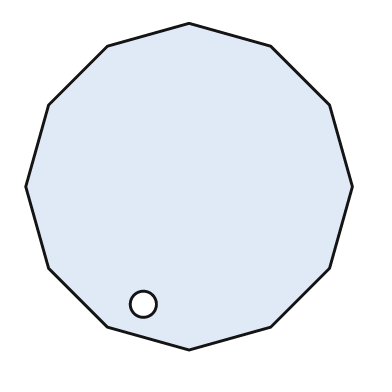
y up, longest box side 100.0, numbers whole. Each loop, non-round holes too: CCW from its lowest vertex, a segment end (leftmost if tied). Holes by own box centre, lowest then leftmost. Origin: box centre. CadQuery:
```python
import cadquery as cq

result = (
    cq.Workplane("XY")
    .moveTo(0.0, -50.0)
    .lineTo(25.0, -43.0)
    .lineTo(43.0, -25.0)
    .lineTo(50.0, 0.0)
    .lineTo(43.0, 25.0)
    .lineTo(25.0, 43.0)
    .lineTo(0.0, 50.0)
    .lineTo(-25.0, 43.0)
    .lineTo(-43.0, 25.0)
    .lineTo(-50.0, 0.0)
    .lineTo(-43.0, -25.0)
    .lineTo(-25.0, -43.0)
    .close()
    .moveTo(-14.0, -36.0)
    .circle(4.0)
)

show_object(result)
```